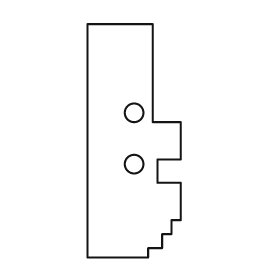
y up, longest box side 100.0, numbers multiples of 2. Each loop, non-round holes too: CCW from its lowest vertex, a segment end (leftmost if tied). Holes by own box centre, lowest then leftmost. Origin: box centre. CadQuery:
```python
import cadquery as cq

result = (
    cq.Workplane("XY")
    .moveTo(-20.0, -50.0)
    .lineTo(6.0, -50.0)
    .lineTo(6.0, -46.0)
    .lineTo(12.0, -46.0)
    .lineTo(12.0, -40.0)
    .lineTo(16.0, -40.0)
    .lineTo(16.0, -34.0)
    .lineTo(20.0, -34.0)
    .lineTo(20.0, -18.0)
    .lineTo(10.0, -18.0)
    .lineTo(10.0, -8.0)
    .lineTo(20.0, -8.0)
    .lineTo(20.0, 8.0)
    .lineTo(8.0, 8.0)
    .lineTo(8.0, 50.0)
    .lineTo(-20.0, 50.0)
    .close()
    .moveTo(0.0, -10.0)
    .circle(4.0)
    .moveTo(0.0, 12.0)
    .circle(4.0)
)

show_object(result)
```